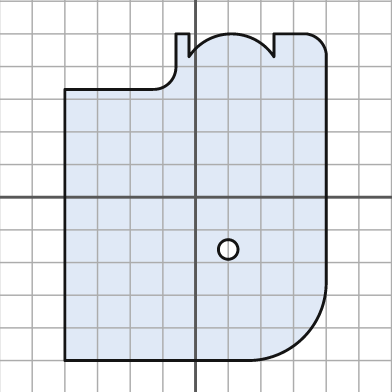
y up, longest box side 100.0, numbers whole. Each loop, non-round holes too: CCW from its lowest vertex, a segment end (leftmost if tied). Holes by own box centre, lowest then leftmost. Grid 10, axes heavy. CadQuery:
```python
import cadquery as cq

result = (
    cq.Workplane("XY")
    .moveTo(-40.0, -50.0)
    .lineTo(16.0, -50.0)
    .threePointArc((33.0, -43.0), (40.0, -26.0))
    .lineTo(40.0, 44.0)
    .threePointArc((38.0, 48.0), (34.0, 50.0))
    .lineTo(24.0, 50.0)
    .lineTo(24.0, 43.0)
    .threePointArc((11.0, 50.0), (-2.0, 43.0))
    .lineTo(-2.0, 50.0)
    .lineTo(-6.0, 50.0)
    .lineTo(-6.0, 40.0)
    .threePointArc((-8.0, 35.0), (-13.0, 33.0))
    .lineTo(-40.0, 33.0)
    .close()
    .moveTo(10.0, -16.0)
    .circle(3.0)
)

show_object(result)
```